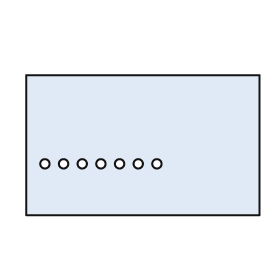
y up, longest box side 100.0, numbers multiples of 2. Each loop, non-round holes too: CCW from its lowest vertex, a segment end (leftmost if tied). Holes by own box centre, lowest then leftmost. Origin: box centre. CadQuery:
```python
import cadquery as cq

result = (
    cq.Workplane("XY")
    .moveTo(-50.0, -30.0)
    .lineTo(50.0, -30.0)
    .lineTo(50.0, 30.0)
    .lineTo(-50.0, 30.0)
    .close()
    .moveTo(-42.0, -8.0)
    .circle(2.0)
    .moveTo(-34.0, -8.0)
    .circle(2.0)
    .moveTo(-26.0, -8.0)
    .circle(2.0)
    .moveTo(-18.0, -8.0)
    .circle(2.0)
    .moveTo(-10.0, -8.0)
    .circle(2.0)
    .moveTo(-2.0, -8.0)
    .circle(2.0)
    .moveTo(6.0, -8.0)
    .circle(2.0)
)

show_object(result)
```